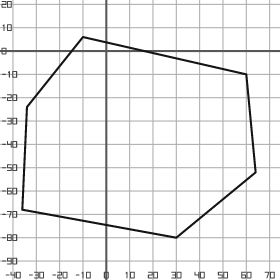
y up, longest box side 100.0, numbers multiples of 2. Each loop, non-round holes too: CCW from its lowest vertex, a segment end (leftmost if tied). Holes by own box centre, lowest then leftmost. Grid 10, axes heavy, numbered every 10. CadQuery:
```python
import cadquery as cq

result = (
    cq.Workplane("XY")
    .moveTo(30.0, -80.0)
    .lineTo(64.0, -52.0)
    .lineTo(60.0, -10.0)
    .lineTo(-10.0, 6.0)
    .lineTo(-34.0, -24.0)
    .lineTo(-36.0, -68.0)
    .close()
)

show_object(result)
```